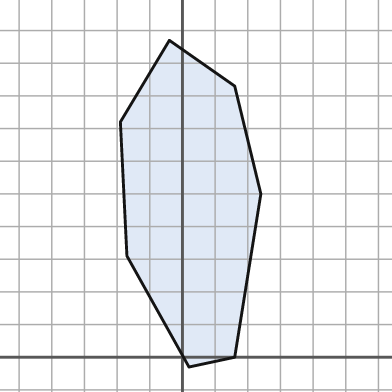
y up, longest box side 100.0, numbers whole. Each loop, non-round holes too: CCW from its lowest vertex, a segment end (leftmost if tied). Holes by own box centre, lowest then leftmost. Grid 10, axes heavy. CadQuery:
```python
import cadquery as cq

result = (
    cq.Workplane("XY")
    .moveTo(2.0, -3.0)
    .lineTo(16.0, 0.0)
    .lineTo(24.0, 50.0)
    .lineTo(16.0, 83.0)
    .lineTo(-4.0, 97.0)
    .lineTo(-19.0, 72.0)
    .lineTo(-17.0, 31.0)
    .close()
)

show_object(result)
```